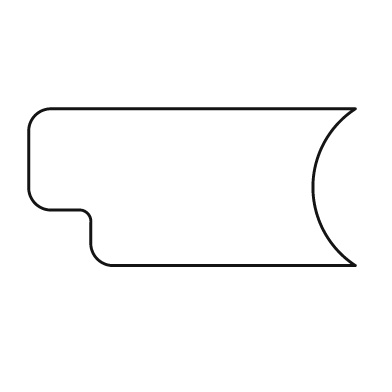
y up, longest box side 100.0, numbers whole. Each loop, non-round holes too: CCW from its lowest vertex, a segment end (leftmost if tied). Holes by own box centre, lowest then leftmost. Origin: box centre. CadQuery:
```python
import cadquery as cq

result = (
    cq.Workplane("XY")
    .moveTo(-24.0, -24.0)
    .lineTo(50.0, -24.0)
    .threePointArc((37.0, 0.0), (50.0, 24.0))
    .lineTo(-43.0, 24.0)
    .threePointArc((-48.0, 22.0), (-50.0, 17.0))
    .lineTo(-50.0, 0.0)
    .threePointArc((-48.0, -5.0), (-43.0, -7.0))
    .lineTo(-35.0, -7.0)
    .threePointArc((-32.0, -8.0), (-31.0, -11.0))
    .lineTo(-31.0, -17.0)
    .threePointArc((-29.0, -22.0), (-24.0, -24.0))
    .close()
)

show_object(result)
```